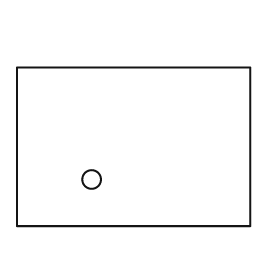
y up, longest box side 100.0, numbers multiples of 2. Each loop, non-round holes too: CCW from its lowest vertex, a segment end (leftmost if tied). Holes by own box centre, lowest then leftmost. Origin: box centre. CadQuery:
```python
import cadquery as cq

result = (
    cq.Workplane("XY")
    .moveTo(-50.0, -34.0)
    .lineTo(50.0, -34.0)
    .lineTo(50.0, 34.0)
    .lineTo(-50.0, 34.0)
    .close()
    .moveTo(-18.0, -14.0)
    .circle(4.0)
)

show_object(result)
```